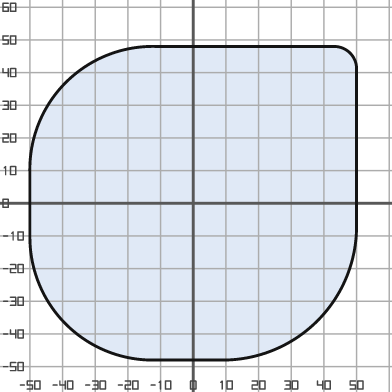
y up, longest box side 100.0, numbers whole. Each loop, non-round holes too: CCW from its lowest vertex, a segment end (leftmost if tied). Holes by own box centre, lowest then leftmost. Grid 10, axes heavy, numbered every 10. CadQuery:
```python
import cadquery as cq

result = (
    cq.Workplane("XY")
    .moveTo(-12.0, -48.0)
    .lineTo(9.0, -48.0)
    .threePointArc((38.0, -36.0), (50.0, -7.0))
    .lineTo(50.0, 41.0)
    .threePointArc((48.0, 46.0), (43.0, 48.0))
    .lineTo(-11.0, 48.0)
    .threePointArc((-39.0, 37.0), (-50.0, 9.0))
    .lineTo(-50.0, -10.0)
    .threePointArc((-39.0, -37.0), (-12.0, -48.0))
    .close()
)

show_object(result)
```